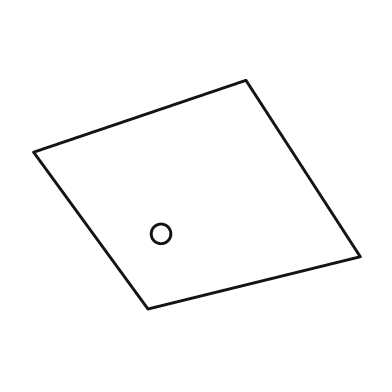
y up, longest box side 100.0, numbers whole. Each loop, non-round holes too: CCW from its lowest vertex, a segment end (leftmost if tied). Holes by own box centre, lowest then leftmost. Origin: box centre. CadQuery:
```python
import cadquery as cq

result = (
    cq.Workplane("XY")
    .moveTo(-15.0, -35.0)
    .lineTo(50.0, -19.0)
    .lineTo(15.0, 35.0)
    .lineTo(-50.0, 13.0)
    .close()
    .moveTo(-11.0, -12.0)
    .circle(3.0)
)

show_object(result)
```